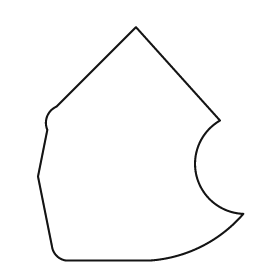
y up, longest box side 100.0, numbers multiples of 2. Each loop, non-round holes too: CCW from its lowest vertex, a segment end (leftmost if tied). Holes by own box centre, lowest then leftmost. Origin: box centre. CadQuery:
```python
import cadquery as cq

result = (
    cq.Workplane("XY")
    .moveTo(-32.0, -50.0)
    .lineTo(4.0, -50.0)
    .threePointArc((26.0, -44.0), (44.0, -30.0))
    .threePointArc((24.0, -14.0), (34.0, 10.0))
    .lineTo(-2.0, 50.0)
    .lineTo(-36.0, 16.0)
    .threePointArc((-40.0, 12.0), (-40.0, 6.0))
    .lineTo(-44.0, -14.0)
    .lineTo(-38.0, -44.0)
    .threePointArc((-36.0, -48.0), (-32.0, -50.0))
    .close()
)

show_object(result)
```